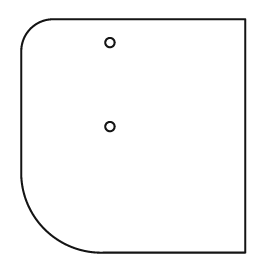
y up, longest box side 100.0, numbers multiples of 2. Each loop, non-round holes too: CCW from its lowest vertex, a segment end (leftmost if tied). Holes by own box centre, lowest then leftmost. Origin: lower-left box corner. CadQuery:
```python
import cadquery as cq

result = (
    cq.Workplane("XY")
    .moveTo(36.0, 0.0)
    .lineTo(96.0, 0.0)
    .lineTo(96.0, 100.0)
    .lineTo(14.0, 100.0)
    .threePointArc((4.0, 96.0), (0.0, 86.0))
    .lineTo(0.0, 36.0)
    .threePointArc((10.0, 10.0), (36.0, 0.0))
    .close()
    .moveTo(38.0, 54.0)
    .circle(2.0)
    .moveTo(38.0, 90.0)
    .circle(2.0)
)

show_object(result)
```